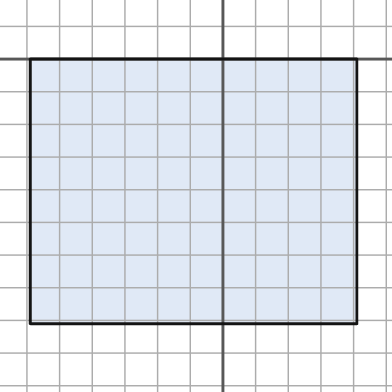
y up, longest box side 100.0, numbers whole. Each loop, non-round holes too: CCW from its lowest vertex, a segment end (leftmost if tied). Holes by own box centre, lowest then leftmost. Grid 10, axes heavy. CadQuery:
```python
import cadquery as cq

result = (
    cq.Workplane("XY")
    .moveTo(-59.0, -81.0)
    .lineTo(41.0, -81.0)
    .lineTo(41.0, 0.0)
    .lineTo(-59.0, 0.0)
    .close()
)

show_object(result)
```